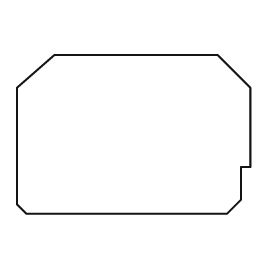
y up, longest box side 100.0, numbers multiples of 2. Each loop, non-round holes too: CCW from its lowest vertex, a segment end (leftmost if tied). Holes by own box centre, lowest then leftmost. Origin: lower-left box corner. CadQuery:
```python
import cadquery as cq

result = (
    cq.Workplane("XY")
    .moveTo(4.0, 0.0)
    .lineTo(90.0, 0.0)
    .lineTo(96.0, 6.0)
    .lineTo(96.0, 20.0)
    .lineTo(100.0, 20.0)
    .lineTo(100.0, 54.0)
    .lineTo(86.0, 68.0)
    .lineTo(16.0, 68.0)
    .lineTo(0.0, 54.0)
    .lineTo(0.0, 4.0)
    .close()
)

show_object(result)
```